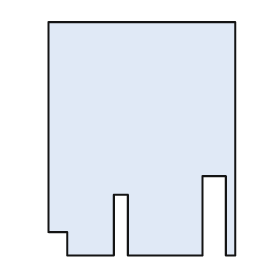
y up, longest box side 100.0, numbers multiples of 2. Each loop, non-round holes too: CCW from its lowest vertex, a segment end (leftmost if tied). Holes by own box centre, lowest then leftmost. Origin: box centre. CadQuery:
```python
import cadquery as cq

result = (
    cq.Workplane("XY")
    .moveTo(-32.0, -50.0)
    .lineTo(-12.0, -50.0)
    .lineTo(-12.0, -24.0)
    .lineTo(-6.0, -24.0)
    .lineTo(-6.0, -50.0)
    .lineTo(26.0, -50.0)
    .lineTo(26.0, -16.0)
    .lineTo(36.0, -16.0)
    .lineTo(36.0, -50.0)
    .lineTo(40.0, -50.0)
    .lineTo(40.0, 50.0)
    .lineTo(-40.0, 50.0)
    .lineTo(-40.0, -40.0)
    .lineTo(-32.0, -40.0)
    .close()
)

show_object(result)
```